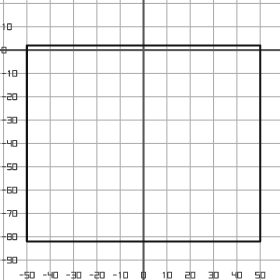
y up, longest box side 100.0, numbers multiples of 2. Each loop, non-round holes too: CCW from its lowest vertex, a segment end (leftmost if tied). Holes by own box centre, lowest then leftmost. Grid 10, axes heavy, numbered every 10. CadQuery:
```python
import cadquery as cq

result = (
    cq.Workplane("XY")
    .moveTo(-50.0, -82.0)
    .lineTo(50.0, -82.0)
    .lineTo(50.0, 2.0)
    .lineTo(-50.0, 2.0)
    .close()
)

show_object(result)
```